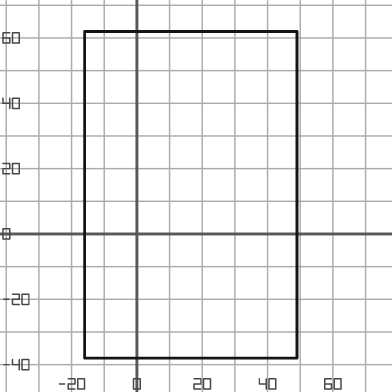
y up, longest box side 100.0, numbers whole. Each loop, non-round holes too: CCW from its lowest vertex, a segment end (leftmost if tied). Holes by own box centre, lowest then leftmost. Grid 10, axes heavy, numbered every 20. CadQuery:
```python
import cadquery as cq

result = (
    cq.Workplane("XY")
    .moveTo(-16.0, -38.0)
    .lineTo(49.0, -38.0)
    .lineTo(49.0, 62.0)
    .lineTo(-16.0, 62.0)
    .close()
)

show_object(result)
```